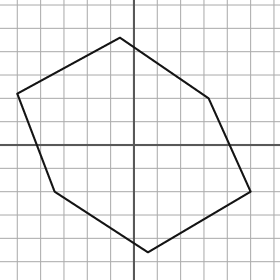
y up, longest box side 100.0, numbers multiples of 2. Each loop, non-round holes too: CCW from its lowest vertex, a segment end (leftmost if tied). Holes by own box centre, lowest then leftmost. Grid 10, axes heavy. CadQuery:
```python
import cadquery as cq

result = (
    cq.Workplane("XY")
    .moveTo(6.0, -46.0)
    .lineTo(50.0, -20.0)
    .lineTo(32.0, 20.0)
    .lineTo(-6.0, 46.0)
    .lineTo(-50.0, 22.0)
    .lineTo(-34.0, -20.0)
    .close()
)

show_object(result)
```